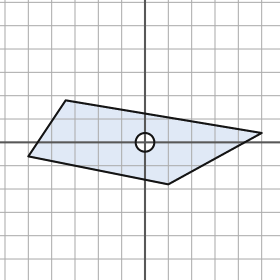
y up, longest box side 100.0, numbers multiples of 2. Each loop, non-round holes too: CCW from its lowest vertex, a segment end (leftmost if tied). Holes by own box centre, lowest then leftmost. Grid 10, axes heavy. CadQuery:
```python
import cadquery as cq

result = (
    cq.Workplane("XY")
    .moveTo(10.0, -18.0)
    .lineTo(50.0, 4.0)
    .lineTo(-34.0, 18.0)
    .lineTo(-50.0, -6.0)
    .close()
    .moveTo(0.0, 0.0)
    .circle(4.0)
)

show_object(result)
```